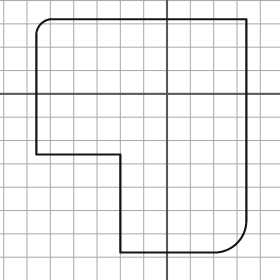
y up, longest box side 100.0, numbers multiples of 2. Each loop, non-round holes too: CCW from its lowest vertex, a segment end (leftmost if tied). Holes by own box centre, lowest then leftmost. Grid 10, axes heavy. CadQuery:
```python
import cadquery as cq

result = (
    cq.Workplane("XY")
    .moveTo(-20.0, -68.0)
    .lineTo(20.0, -68.0)
    .threePointArc((30.0, -64.0), (34.0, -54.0))
    .lineTo(34.0, 32.0)
    .lineTo(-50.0, 32.0)
    .threePointArc((-54.0, 30.0), (-56.0, 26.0))
    .lineTo(-56.0, -26.0)
    .lineTo(-20.0, -26.0)
    .close()
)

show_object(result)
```